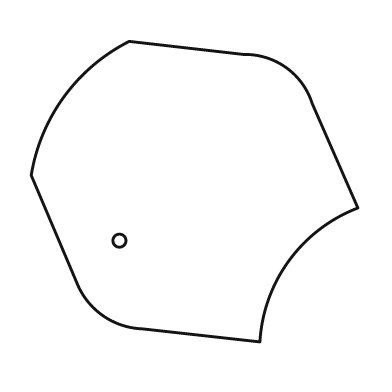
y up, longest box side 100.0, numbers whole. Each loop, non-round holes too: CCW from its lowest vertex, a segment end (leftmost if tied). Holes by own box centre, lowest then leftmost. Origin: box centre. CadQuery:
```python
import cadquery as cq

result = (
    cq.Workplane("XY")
    .moveTo(20.0, -46.0)
    .threePointArc((29.0, -21.0), (50.0, -5.0))
    .lineTo(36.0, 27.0)
    .threePointArc((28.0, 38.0), (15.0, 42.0))
    .lineTo(-20.0, 46.0)
    .threePointArc((-40.0, 29.0), (-50.0, 5.0))
    .lineTo(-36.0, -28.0)
    .threePointArc((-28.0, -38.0), (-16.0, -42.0))
    .close()
    .moveTo(-23.0, -15.0)
    .circle(2.0)
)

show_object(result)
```